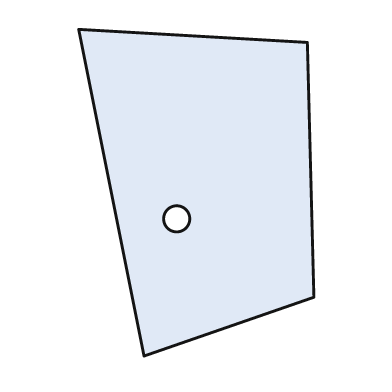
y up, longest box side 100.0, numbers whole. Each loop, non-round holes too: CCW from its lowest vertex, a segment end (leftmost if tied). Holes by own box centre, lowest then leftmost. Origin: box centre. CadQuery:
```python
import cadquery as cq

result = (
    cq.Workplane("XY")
    .moveTo(-16.0, -50.0)
    .lineTo(36.0, -32.0)
    .lineTo(34.0, 46.0)
    .lineTo(-36.0, 50.0)
    .close()
    .moveTo(-6.0, -8.0)
    .circle(4.0)
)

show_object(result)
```